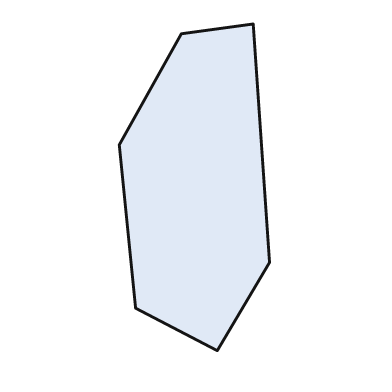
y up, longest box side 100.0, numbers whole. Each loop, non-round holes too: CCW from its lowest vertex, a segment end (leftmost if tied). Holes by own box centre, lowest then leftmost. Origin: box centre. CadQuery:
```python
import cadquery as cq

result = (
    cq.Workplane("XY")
    .moveTo(7.0, -50.0)
    .lineTo(23.0, -23.0)
    .lineTo(18.0, 50.0)
    .lineTo(-4.0, 47.0)
    .lineTo(-23.0, 13.0)
    .lineTo(-18.0, -37.0)
    .close()
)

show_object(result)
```